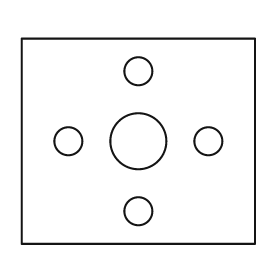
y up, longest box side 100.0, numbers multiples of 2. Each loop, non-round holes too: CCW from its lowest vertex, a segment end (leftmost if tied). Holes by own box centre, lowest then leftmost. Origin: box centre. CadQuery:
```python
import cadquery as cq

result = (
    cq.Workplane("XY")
    .moveTo(-50.0, -44.0)
    .lineTo(50.0, -44.0)
    .lineTo(50.0, 44.0)
    .lineTo(-50.0, 44.0)
    .close()
    .moveTo(0.0, -30.0)
    .circle(6.0)
    .moveTo(-30.0, 0.0)
    .circle(6.0)
    .moveTo(0.0, 0.0)
    .circle(12.0)
    .moveTo(30.0, 0.0)
    .circle(6.0)
    .moveTo(0.0, 30.0)
    .circle(6.0)
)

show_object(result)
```